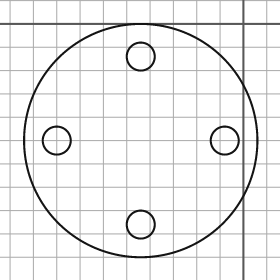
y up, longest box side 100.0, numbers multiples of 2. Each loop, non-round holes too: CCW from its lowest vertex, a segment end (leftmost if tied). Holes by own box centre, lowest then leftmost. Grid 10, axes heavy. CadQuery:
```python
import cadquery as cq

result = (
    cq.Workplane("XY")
    .moveTo(-44.0, -50.0)
    .circle(50.0)
    .moveTo(-44.0, -86.0)
    .circle(6.0)
    .moveTo(-80.0, -50.0)
    .circle(6.0)
    .moveTo(-8.0, -50.0)
    .circle(6.0)
    .moveTo(-44.0, -14.0)
    .circle(6.0)
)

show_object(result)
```